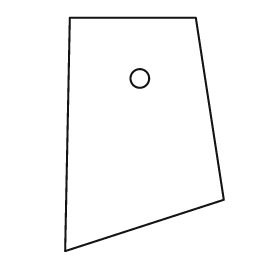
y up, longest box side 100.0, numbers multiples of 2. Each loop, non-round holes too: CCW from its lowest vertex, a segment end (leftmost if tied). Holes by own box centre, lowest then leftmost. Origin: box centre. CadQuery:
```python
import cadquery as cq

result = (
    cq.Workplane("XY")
    .moveTo(-34.0, -50.0)
    .lineTo(34.0, -28.0)
    .lineTo(22.0, 50.0)
    .lineTo(-32.0, 50.0)
    .close()
    .moveTo(-2.0, 24.0)
    .circle(4.0)
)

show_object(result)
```